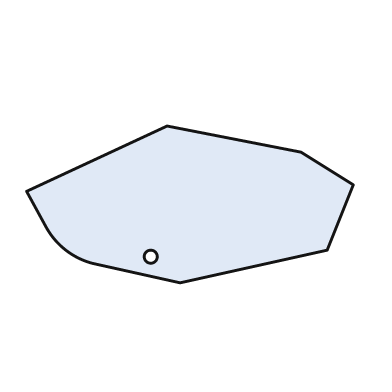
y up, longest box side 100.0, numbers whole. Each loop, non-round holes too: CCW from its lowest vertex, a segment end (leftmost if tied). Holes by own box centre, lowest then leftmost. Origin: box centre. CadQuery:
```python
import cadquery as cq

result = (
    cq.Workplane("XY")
    .moveTo(-3.0, -24.0)
    .lineTo(42.0, -14.0)
    .lineTo(50.0, 6.0)
    .lineTo(34.0, 16.0)
    .lineTo(-7.0, 24.0)
    .lineTo(-50.0, 4.0)
    .lineTo(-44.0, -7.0)
    .threePointArc((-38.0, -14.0), (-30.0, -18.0))
    .close()
    .moveTo(-12.0, -16.0)
    .circle(2.0)
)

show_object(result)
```